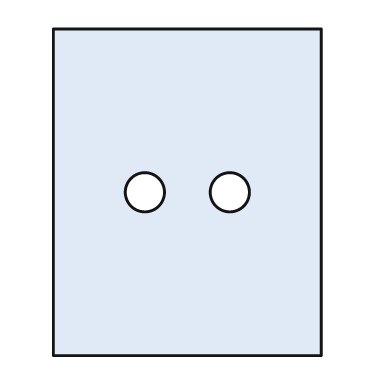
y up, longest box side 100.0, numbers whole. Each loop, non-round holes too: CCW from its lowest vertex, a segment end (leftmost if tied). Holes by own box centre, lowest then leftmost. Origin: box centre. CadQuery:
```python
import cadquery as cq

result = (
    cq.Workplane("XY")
    .moveTo(-41.0, -50.0)
    .lineTo(41.0, -50.0)
    .lineTo(41.0, 50.0)
    .lineTo(-41.0, 50.0)
    .close()
    .moveTo(-13.0, 0.0)
    .circle(6.0)
    .moveTo(13.0, 0.0)
    .circle(6.0)
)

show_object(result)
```